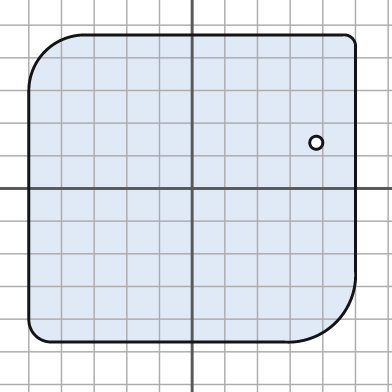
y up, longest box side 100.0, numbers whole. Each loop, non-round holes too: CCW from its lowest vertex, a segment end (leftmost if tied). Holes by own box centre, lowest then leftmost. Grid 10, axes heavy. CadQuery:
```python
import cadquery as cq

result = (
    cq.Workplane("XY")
    .moveTo(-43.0, -47.0)
    .lineTo(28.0, -47.0)
    .threePointArc((44.0, -41.0), (50.0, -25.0))
    .lineTo(50.0, 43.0)
    .threePointArc((49.0, 46.0), (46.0, 47.0))
    .lineTo(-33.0, 47.0)
    .threePointArc((-45.0, 42.0), (-50.0, 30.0))
    .lineTo(-50.0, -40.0)
    .threePointArc((-48.0, -45.0), (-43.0, -47.0))
    .close()
    .moveTo(38.0, 14.0)
    .circle(2.0)
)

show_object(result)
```